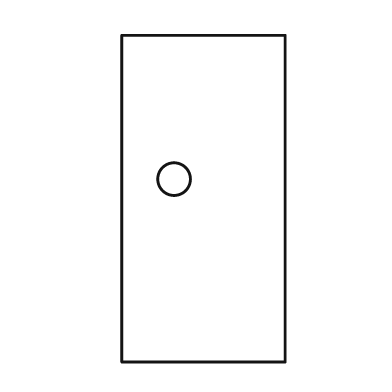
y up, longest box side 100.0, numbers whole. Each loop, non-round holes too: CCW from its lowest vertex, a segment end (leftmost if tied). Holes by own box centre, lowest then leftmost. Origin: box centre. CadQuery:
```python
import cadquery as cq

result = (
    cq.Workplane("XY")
    .moveTo(-25.0, -50.0)
    .lineTo(25.0, -50.0)
    .lineTo(25.0, 50.0)
    .lineTo(-25.0, 50.0)
    .close()
    .moveTo(-9.0, 6.0)
    .circle(5.0)
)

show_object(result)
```